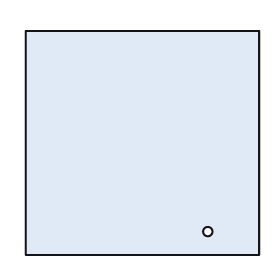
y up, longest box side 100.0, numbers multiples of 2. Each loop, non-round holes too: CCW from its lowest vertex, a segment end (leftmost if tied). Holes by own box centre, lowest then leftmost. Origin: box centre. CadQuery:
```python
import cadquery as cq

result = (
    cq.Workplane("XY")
    .moveTo(-50.0, -48.0)
    .lineTo(50.0, -48.0)
    .lineTo(50.0, 48.0)
    .lineTo(-50.0, 48.0)
    .close()
    .moveTo(28.0, -38.0)
    .circle(2.0)
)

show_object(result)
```